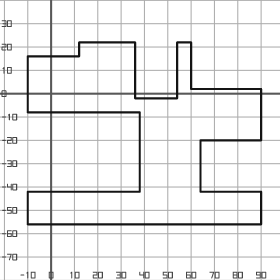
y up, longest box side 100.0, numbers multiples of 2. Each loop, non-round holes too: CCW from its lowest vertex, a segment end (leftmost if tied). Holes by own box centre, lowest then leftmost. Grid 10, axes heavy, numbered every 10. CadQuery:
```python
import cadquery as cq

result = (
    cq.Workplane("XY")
    .moveTo(-10.0, -56.0)
    .lineTo(90.0, -56.0)
    .lineTo(90.0, -42.0)
    .lineTo(64.0, -42.0)
    .lineTo(64.0, -20.0)
    .lineTo(90.0, -20.0)
    .lineTo(90.0, 2.0)
    .lineTo(60.0, 2.0)
    .lineTo(60.0, 22.0)
    .lineTo(54.0, 22.0)
    .lineTo(54.0, -2.0)
    .lineTo(36.0, -2.0)
    .lineTo(36.0, 22.0)
    .lineTo(12.0, 22.0)
    .lineTo(12.0, 16.0)
    .lineTo(-10.0, 16.0)
    .lineTo(-10.0, -8.0)
    .lineTo(38.0, -8.0)
    .lineTo(38.0, -42.0)
    .lineTo(-10.0, -42.0)
    .close()
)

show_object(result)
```